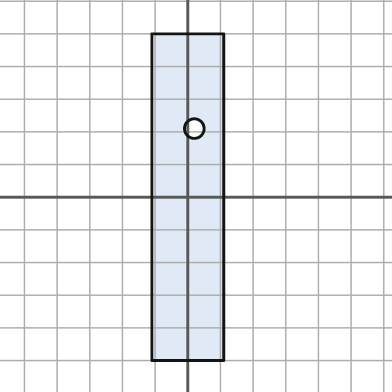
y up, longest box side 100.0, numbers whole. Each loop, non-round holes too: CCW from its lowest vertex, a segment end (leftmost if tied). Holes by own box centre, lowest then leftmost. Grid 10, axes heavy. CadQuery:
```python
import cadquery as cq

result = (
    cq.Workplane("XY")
    .moveTo(-11.0, -50.0)
    .lineTo(11.0, -50.0)
    .lineTo(11.0, 50.0)
    .lineTo(-11.0, 50.0)
    .close()
    .moveTo(2.0, 21.0)
    .circle(3.0)
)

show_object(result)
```